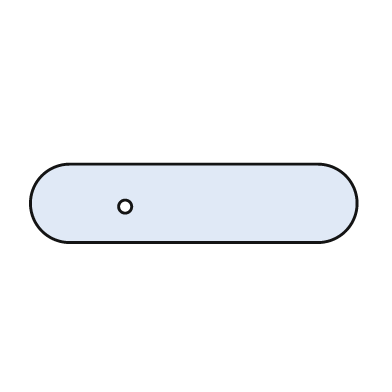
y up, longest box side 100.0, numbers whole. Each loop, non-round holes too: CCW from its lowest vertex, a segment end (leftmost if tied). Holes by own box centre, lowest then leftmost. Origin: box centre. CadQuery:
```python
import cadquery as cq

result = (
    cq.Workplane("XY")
    .moveTo(-38.0, -12.0)
    .lineTo(38.0, -12.0)
    .threePointArc((50.0, 0.0), (38.0, 12.0))
    .lineTo(-38.0, 12.0)
    .threePointArc((-50.0, 0.0), (-38.0, -12.0))
    .close()
    .moveTo(-21.0, -1.0)
    .circle(2.0)
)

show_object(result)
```